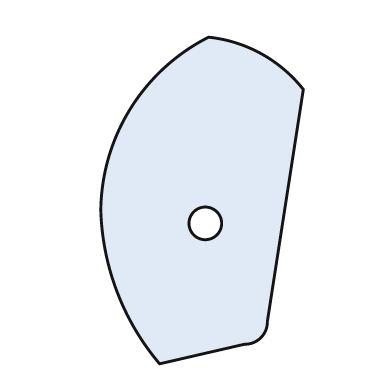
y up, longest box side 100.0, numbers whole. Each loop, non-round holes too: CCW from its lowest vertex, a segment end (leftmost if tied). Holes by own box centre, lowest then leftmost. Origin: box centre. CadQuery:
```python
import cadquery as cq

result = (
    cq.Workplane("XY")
    .moveTo(-13.0, -50.0)
    .lineTo(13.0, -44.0)
    .threePointArc((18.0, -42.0), (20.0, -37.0))
    .lineTo(31.0, 34.0)
    .threePointArc((18.0, 45.0), (2.0, 50.0))
    .threePointArc((-22.0, 28.0), (-31.0, -3.0))
    .threePointArc((-26.0, -28.0), (-13.0, -50.0))
    .close()
    .moveTo(1.0, -7.0)
    .circle(5.0)
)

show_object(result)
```